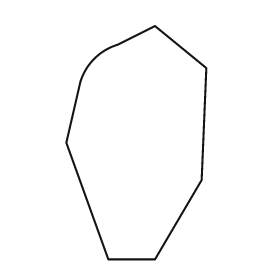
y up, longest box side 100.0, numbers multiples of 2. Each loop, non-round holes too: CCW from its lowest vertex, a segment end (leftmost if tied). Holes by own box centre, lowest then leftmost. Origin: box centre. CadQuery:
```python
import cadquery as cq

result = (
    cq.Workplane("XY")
    .moveTo(-12.0, -50.0)
    .lineTo(8.0, -50.0)
    .lineTo(28.0, -16.0)
    .lineTo(30.0, 32.0)
    .lineTo(8.0, 50.0)
    .lineTo(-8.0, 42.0)
    .threePointArc((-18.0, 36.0), (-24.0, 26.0))
    .lineTo(-30.0, 0.0)
    .close()
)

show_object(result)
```